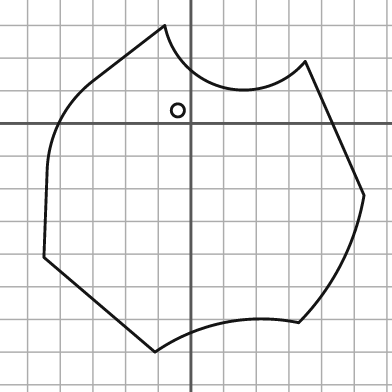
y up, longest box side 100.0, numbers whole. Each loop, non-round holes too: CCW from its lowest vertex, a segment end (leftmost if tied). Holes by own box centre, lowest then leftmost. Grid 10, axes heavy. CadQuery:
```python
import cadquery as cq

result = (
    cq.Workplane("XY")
    .moveTo(-11.0, -70.0)
    .threePointArc((10.0, -61.0), (33.0, -61.0))
    .threePointArc((46.0, -43.0), (53.0, -22.0))
    .lineTo(35.0, 19.0)
    .threePointArc((10.0, 11.0), (-8.0, 30.0))
    .lineTo(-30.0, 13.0)
    .threePointArc((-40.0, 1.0), (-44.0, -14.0))
    .lineTo(-45.0, -41.0)
    .close()
    .moveTo(-4.0, 4.0)
    .circle(2.0)
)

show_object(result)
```